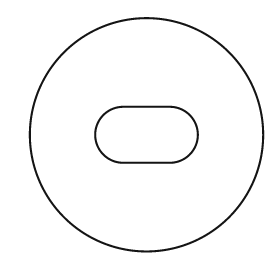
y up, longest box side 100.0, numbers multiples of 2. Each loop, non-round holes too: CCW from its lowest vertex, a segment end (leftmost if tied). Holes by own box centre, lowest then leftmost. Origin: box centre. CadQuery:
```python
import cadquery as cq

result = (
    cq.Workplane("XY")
    .moveTo(0.0, 0.0)
    .circle(50.0)
    .moveTo(-10.0, -12.0)
    .lineTo(10.0, -12.0)
    .threePointArc((22.0, 0.0), (10.0, 12.0))
    .lineTo(-10.0, 12.0)
    .threePointArc((-22.0, 0.0), (-10.0, -12.0))
    .close()
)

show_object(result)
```